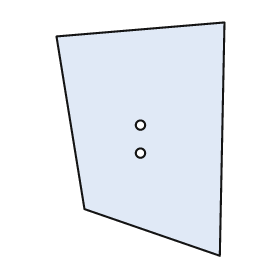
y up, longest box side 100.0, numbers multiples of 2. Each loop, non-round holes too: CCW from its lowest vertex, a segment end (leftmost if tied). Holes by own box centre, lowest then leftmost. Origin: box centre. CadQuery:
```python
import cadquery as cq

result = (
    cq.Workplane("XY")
    .moveTo(34.0, -50.0)
    .lineTo(36.0, 50.0)
    .lineTo(-36.0, 44.0)
    .lineTo(-24.0, -30.0)
    .close()
    .moveTo(0.0, -6.0)
    .circle(2.0)
    .moveTo(0.0, 6.0)
    .circle(2.0)
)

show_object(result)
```